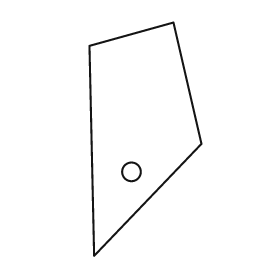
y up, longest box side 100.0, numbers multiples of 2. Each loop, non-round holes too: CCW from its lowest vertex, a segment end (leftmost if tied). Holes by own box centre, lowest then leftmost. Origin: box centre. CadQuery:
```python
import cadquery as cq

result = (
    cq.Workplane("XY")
    .moveTo(-22.0, -50.0)
    .lineTo(24.0, -2.0)
    .lineTo(12.0, 50.0)
    .lineTo(-24.0, 40.0)
    .close()
    .moveTo(-6.0, -14.0)
    .circle(4.0)
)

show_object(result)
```